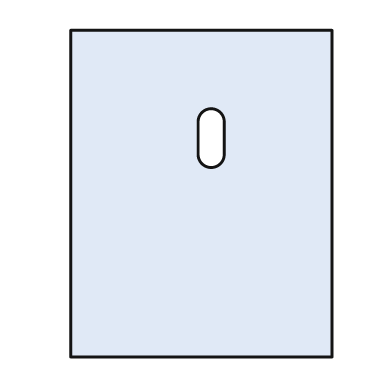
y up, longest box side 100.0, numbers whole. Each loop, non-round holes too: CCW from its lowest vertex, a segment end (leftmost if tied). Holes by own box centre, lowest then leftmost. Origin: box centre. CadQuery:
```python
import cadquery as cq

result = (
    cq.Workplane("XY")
    .moveTo(-40.0, -50.0)
    .lineTo(40.0, -50.0)
    .lineTo(40.0, 50.0)
    .lineTo(-40.0, 50.0)
    .close()
    .moveTo(-1.0, 12.0)
    .threePointArc((3.0, 8.0), (7.0, 12.0))
    .lineTo(7.0, 22.0)
    .threePointArc((3.0, 26.0), (-1.0, 22.0))
    .close()
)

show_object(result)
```